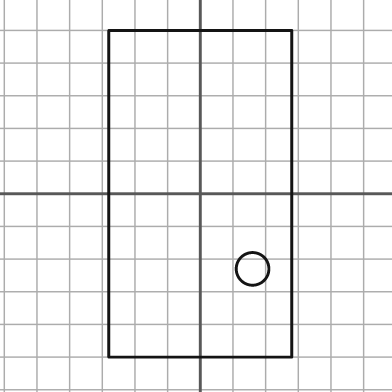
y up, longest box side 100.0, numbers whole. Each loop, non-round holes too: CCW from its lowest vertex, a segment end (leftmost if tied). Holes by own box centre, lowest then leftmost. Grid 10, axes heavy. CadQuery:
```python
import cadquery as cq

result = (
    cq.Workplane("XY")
    .moveTo(-28.0, -50.0)
    .lineTo(28.0, -50.0)
    .lineTo(28.0, 50.0)
    .lineTo(-28.0, 50.0)
    .close()
    .moveTo(16.0, -23.0)
    .circle(5.0)
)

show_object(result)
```